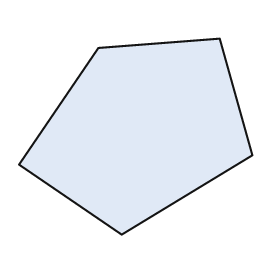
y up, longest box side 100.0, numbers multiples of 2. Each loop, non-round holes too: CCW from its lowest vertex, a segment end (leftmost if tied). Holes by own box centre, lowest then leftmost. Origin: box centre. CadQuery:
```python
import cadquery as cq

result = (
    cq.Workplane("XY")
    .moveTo(-6.0, -42.0)
    .lineTo(50.0, -8.0)
    .lineTo(36.0, 42.0)
    .lineTo(-16.0, 38.0)
    .lineTo(-50.0, -12.0)
    .close()
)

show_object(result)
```